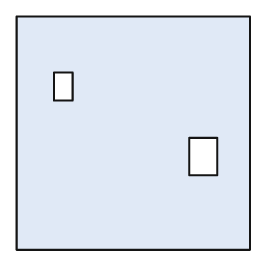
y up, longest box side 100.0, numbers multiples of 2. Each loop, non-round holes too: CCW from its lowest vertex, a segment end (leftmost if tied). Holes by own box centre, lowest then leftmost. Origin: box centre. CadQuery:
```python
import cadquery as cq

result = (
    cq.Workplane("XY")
    .moveTo(-50.0, -50.0)
    .lineTo(50.0, -50.0)
    .lineTo(50.0, 50.0)
    .lineTo(-50.0, 50.0)
    .close()
    .moveTo(24.0, -18.0)
    .lineTo(36.0, -18.0)
    .lineTo(36.0, -2.0)
    .lineTo(24.0, -2.0)
    .close()
    .moveTo(-34.0, 14.0)
    .lineTo(-26.0, 14.0)
    .lineTo(-26.0, 26.0)
    .lineTo(-34.0, 26.0)
    .close()
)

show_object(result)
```